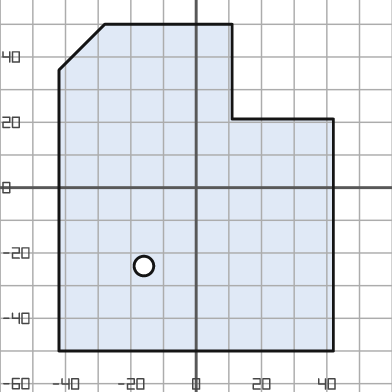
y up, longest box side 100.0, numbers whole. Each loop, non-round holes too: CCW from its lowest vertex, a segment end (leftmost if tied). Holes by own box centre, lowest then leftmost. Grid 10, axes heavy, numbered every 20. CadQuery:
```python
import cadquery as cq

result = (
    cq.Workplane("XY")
    .moveTo(-42.0, -50.0)
    .lineTo(42.0, -50.0)
    .lineTo(42.0, 21.0)
    .lineTo(11.0, 21.0)
    .lineTo(11.0, 50.0)
    .lineTo(-28.0, 50.0)
    .lineTo(-42.0, 36.0)
    .close()
    .moveTo(-16.0, -24.0)
    .circle(3.0)
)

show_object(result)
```